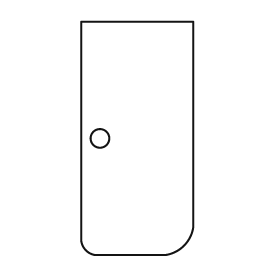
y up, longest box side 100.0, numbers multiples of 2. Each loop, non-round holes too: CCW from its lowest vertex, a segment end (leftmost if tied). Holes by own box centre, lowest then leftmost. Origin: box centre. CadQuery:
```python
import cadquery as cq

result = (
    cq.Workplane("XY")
    .moveTo(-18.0, -50.0)
    .lineTo(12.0, -50.0)
    .threePointArc((20.0, -46.0), (24.0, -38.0))
    .lineTo(24.0, 50.0)
    .lineTo(-24.0, 50.0)
    .lineTo(-24.0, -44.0)
    .threePointArc((-22.0, -48.0), (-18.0, -50.0))
    .close()
    .moveTo(-16.0, 0.0)
    .circle(4.0)
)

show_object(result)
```